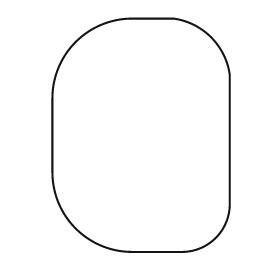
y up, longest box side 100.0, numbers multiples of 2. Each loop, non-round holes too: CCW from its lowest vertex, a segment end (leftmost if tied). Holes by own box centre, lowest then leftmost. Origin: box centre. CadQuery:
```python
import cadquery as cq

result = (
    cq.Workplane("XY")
    .moveTo(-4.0, -50.0)
    .lineTo(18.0, -50.0)
    .threePointArc((32.0, -44.0), (38.0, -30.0))
    .lineTo(38.0, 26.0)
    .threePointArc((30.0, 42.0), (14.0, 50.0))
    .lineTo(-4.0, 50.0)
    .threePointArc((-28.0, 40.0), (-38.0, 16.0))
    .lineTo(-38.0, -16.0)
    .threePointArc((-28.0, -40.0), (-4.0, -50.0))
    .close()
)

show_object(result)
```